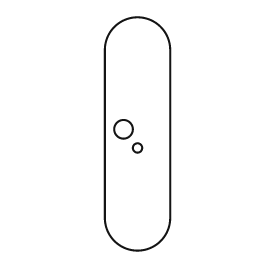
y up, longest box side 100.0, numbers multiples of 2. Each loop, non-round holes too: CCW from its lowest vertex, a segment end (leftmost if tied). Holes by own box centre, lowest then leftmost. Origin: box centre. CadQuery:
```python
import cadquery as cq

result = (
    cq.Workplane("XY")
    .moveTo(-14.0, -36.0)
    .threePointArc((0.0, -50.0), (14.0, -36.0))
    .lineTo(14.0, 36.0)
    .threePointArc((0.0, 50.0), (-14.0, 36.0))
    .close()
    .moveTo(0.0, -6.0)
    .circle(2.0)
    .moveTo(-6.0, 2.0)
    .circle(4.0)
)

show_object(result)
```